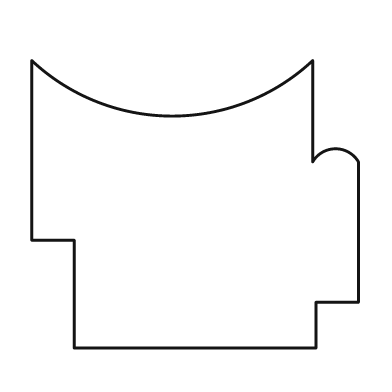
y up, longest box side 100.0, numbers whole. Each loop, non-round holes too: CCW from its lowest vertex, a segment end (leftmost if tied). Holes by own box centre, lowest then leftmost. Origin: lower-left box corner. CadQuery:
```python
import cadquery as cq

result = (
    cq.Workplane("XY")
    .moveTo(13.0, 0.0)
    .lineTo(87.0, 0.0)
    .lineTo(87.0, 14.0)
    .lineTo(100.0, 14.0)
    .lineTo(100.0, 57.0)
    .threePointArc((93.0, 61.0), (86.0, 57.0))
    .lineTo(86.0, 88.0)
    .threePointArc((43.0, 71.0), (0.0, 88.0))
    .lineTo(0.0, 33.0)
    .lineTo(13.0, 33.0)
    .close()
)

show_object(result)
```